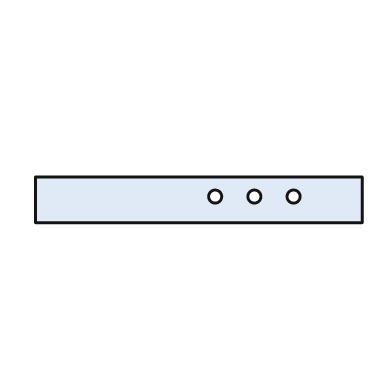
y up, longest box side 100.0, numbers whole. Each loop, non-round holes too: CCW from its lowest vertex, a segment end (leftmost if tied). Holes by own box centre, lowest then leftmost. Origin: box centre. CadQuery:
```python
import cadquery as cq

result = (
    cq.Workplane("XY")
    .moveTo(-50.0, -7.0)
    .lineTo(50.0, -7.0)
    .lineTo(50.0, 7.0)
    .lineTo(-50.0, 7.0)
    .close()
    .moveTo(5.0, 1.0)
    .circle(2.0)
    .moveTo(17.0, 1.0)
    .circle(2.0)
    .moveTo(29.0, 1.0)
    .circle(2.0)
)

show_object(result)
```